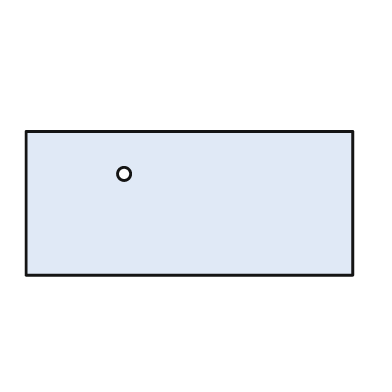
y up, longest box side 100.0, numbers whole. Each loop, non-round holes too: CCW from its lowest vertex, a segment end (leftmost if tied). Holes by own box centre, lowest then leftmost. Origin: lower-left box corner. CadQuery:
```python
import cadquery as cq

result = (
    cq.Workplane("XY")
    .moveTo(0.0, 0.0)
    .lineTo(100.0, 0.0)
    .lineTo(100.0, 44.0)
    .lineTo(0.0, 44.0)
    .close()
    .moveTo(30.0, 31.0)
    .circle(2.0)
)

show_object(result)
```